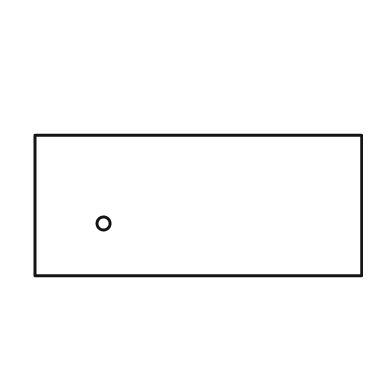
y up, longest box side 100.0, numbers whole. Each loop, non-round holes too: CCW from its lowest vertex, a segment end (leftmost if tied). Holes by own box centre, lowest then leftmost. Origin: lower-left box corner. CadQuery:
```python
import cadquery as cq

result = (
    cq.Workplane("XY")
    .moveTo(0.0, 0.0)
    .lineTo(100.0, 0.0)
    .lineTo(100.0, 43.0)
    .lineTo(0.0, 43.0)
    .close()
    .moveTo(21.0, 16.0)
    .circle(2.0)
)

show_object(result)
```